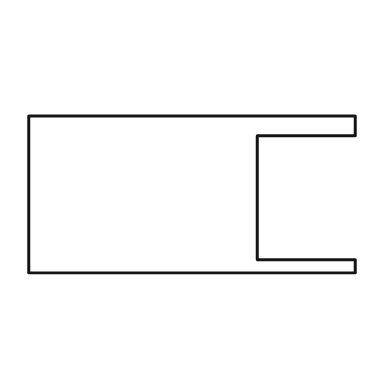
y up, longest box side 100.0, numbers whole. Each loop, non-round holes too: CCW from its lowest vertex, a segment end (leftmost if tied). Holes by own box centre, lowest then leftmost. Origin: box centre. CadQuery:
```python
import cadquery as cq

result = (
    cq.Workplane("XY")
    .moveTo(-50.0, -24.0)
    .lineTo(50.0, -24.0)
    .lineTo(50.0, -20.0)
    .lineTo(20.0, -20.0)
    .lineTo(20.0, 18.0)
    .lineTo(50.0, 18.0)
    .lineTo(50.0, 24.0)
    .lineTo(-50.0, 24.0)
    .close()
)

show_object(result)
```